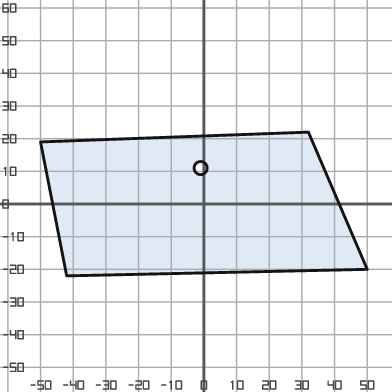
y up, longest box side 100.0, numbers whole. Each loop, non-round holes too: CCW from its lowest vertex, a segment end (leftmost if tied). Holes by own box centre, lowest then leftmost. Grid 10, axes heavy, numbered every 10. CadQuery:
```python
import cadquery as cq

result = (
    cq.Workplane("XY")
    .moveTo(-42.0, -22.0)
    .lineTo(50.0, -20.0)
    .lineTo(32.0, 22.0)
    .lineTo(-50.0, 19.0)
    .close()
    .moveTo(-1.0, 11.0)
    .circle(2.0)
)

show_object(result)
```